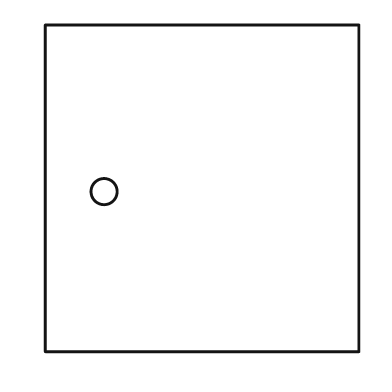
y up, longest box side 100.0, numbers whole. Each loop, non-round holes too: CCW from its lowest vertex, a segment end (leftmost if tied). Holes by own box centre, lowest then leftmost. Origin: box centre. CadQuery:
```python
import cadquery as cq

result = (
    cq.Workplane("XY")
    .moveTo(-48.0, -50.0)
    .lineTo(48.0, -50.0)
    .lineTo(48.0, 50.0)
    .lineTo(-48.0, 50.0)
    .close()
    .moveTo(-30.0, -1.0)
    .circle(4.0)
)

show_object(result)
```